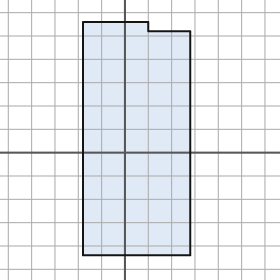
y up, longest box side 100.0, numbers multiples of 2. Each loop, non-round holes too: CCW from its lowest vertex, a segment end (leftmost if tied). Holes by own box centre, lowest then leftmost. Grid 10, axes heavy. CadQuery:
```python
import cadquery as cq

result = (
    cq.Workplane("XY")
    .moveTo(-18.0, -44.0)
    .lineTo(28.0, -44.0)
    .lineTo(28.0, 52.0)
    .lineTo(10.0, 52.0)
    .lineTo(10.0, 56.0)
    .lineTo(-18.0, 56.0)
    .close()
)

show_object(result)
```